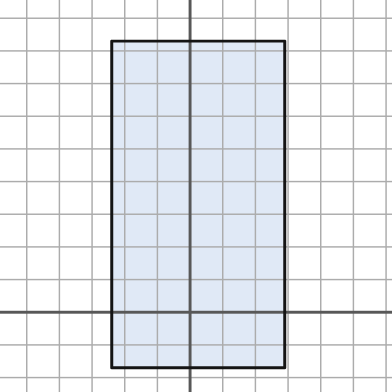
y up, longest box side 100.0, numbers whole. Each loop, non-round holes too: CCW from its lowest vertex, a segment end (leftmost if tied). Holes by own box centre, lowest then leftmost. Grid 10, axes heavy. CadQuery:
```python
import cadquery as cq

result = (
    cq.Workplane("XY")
    .moveTo(-24.0, -17.0)
    .lineTo(29.0, -17.0)
    .lineTo(29.0, 83.0)
    .lineTo(-24.0, 83.0)
    .close()
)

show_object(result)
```